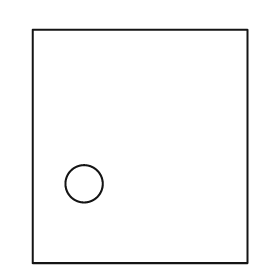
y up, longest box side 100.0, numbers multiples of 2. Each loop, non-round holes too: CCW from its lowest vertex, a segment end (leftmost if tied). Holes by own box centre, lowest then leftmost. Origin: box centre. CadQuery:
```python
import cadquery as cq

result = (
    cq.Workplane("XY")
    .moveTo(-46.0, -50.0)
    .lineTo(46.0, -50.0)
    .lineTo(46.0, 50.0)
    .lineTo(-46.0, 50.0)
    .close()
    .moveTo(-24.0, -16.0)
    .circle(8.0)
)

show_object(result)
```